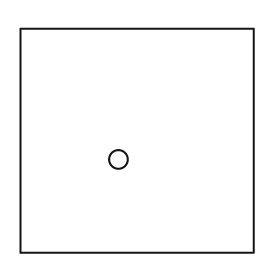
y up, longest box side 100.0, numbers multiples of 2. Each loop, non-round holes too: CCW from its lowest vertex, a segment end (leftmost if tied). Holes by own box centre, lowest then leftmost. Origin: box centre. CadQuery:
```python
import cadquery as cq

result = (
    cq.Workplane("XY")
    .moveTo(-50.0, -48.0)
    .lineTo(50.0, -48.0)
    .lineTo(50.0, 48.0)
    .lineTo(-50.0, 48.0)
    .close()
    .moveTo(-8.0, -8.0)
    .circle(4.0)
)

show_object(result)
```